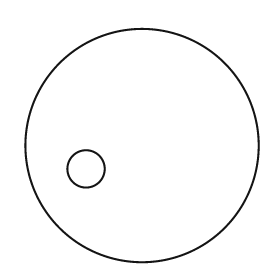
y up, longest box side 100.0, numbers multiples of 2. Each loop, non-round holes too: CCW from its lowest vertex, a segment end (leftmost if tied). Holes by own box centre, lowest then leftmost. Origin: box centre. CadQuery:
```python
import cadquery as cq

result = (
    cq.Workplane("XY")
    .moveTo(0.0, 0.0)
    .circle(50.0)
    .moveTo(-24.0, -10.0)
    .circle(8.0)
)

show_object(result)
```